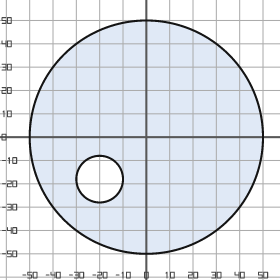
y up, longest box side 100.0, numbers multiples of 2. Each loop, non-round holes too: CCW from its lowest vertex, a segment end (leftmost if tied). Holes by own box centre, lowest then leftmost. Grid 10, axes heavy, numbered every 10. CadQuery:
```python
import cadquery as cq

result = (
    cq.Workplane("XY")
    .moveTo(0.0, 0.0)
    .circle(50.0)
    .moveTo(-20.0, -18.0)
    .circle(10.0)
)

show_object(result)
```